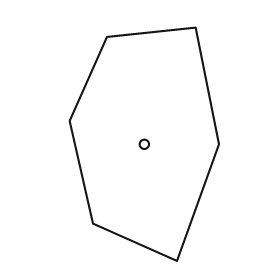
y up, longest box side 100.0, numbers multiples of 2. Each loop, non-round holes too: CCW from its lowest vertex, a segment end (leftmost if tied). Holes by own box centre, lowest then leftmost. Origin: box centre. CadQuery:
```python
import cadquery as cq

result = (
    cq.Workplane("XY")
    .moveTo(14.0, -50.0)
    .lineTo(32.0, 0.0)
    .lineTo(22.0, 50.0)
    .lineTo(-16.0, 46.0)
    .lineTo(-32.0, 10.0)
    .lineTo(-22.0, -34.0)
    .close()
    .moveTo(0.0, 0.0)
    .circle(2.0)
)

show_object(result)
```